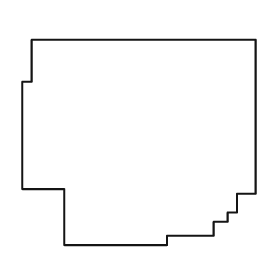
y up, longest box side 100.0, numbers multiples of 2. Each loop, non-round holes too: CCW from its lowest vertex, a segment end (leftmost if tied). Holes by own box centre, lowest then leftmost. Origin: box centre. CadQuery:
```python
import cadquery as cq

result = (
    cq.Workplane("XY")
    .moveTo(-32.0, -44.0)
    .lineTo(12.0, -44.0)
    .lineTo(12.0, -40.0)
    .lineTo(32.0, -40.0)
    .lineTo(32.0, -34.0)
    .lineTo(38.0, -34.0)
    .lineTo(38.0, -30.0)
    .lineTo(42.0, -30.0)
    .lineTo(42.0, -22.0)
    .lineTo(50.0, -22.0)
    .lineTo(50.0, 44.0)
    .lineTo(-46.0, 44.0)
    .lineTo(-46.0, 26.0)
    .lineTo(-50.0, 26.0)
    .lineTo(-50.0, -20.0)
    .lineTo(-32.0, -20.0)
    .close()
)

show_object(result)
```